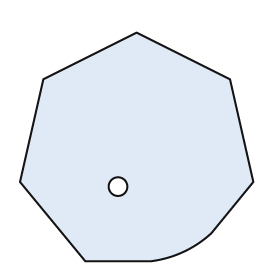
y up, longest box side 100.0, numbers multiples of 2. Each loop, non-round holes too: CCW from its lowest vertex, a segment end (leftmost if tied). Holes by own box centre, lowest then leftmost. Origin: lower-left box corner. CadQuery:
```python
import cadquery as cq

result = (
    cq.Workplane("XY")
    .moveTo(28.0, 0.0)
    .lineTo(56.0, 0.0)
    .threePointArc((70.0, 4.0), (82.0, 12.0))
    .lineTo(100.0, 34.0)
    .lineTo(90.0, 78.0)
    .lineTo(50.0, 98.0)
    .lineTo(10.0, 78.0)
    .lineTo(0.0, 34.0)
    .close()
    .moveTo(42.0, 32.0)
    .circle(4.0)
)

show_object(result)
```